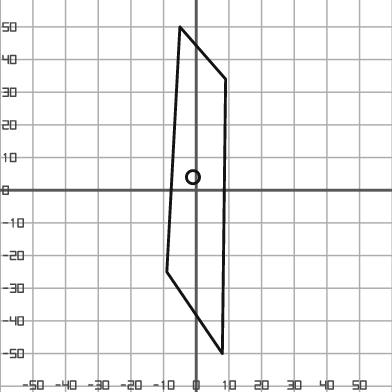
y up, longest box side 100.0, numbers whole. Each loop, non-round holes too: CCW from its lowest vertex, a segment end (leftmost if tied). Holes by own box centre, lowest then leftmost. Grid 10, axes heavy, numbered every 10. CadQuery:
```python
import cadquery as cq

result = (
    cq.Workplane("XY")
    .moveTo(8.0, -50.0)
    .lineTo(9.0, 34.0)
    .lineTo(-5.0, 50.0)
    .lineTo(-9.0, -25.0)
    .close()
    .moveTo(-1.0, 4.0)
    .circle(2.0)
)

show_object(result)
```